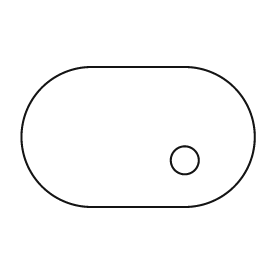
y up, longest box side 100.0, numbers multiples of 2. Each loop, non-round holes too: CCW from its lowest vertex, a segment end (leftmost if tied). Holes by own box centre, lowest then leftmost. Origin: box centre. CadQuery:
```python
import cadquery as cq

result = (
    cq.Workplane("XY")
    .moveTo(-20.0, -30.0)
    .lineTo(20.0, -30.0)
    .threePointArc((50.0, 0.0), (20.0, 30.0))
    .lineTo(-20.0, 30.0)
    .threePointArc((-50.0, 0.0), (-20.0, -30.0))
    .close()
    .moveTo(20.0, -10.0)
    .circle(6.0)
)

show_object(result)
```